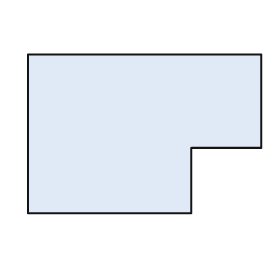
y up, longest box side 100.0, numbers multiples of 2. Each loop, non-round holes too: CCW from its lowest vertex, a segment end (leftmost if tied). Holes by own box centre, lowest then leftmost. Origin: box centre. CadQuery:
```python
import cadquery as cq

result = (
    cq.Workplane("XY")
    .moveTo(-50.0, -34.0)
    .lineTo(20.0, -34.0)
    .lineTo(20.0, -6.0)
    .lineTo(50.0, -6.0)
    .lineTo(50.0, 34.0)
    .lineTo(-50.0, 34.0)
    .close()
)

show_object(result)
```